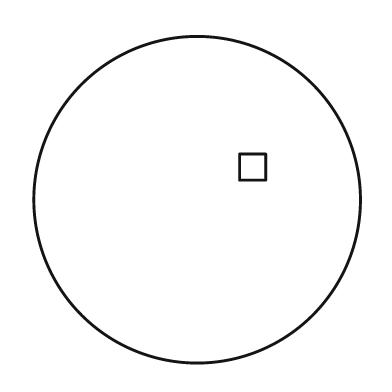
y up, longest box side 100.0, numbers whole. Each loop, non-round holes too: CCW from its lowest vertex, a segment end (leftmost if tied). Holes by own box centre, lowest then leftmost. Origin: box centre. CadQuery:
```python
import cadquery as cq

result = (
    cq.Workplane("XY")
    .moveTo(0.0, 0.0)
    .circle(50.0)
    .moveTo(13.0, 6.0)
    .lineTo(21.0, 6.0)
    .lineTo(21.0, 14.0)
    .lineTo(13.0, 14.0)
    .close()
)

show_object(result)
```